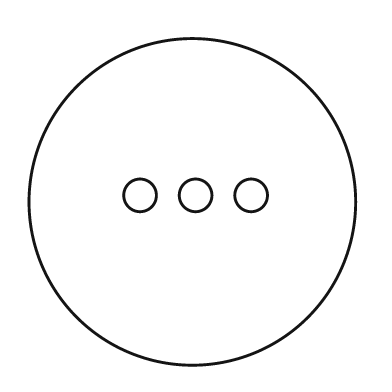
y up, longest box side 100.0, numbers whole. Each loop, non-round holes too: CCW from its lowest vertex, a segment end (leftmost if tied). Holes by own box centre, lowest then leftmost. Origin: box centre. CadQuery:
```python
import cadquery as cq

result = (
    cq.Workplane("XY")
    .moveTo(0.0, 0.0)
    .circle(50.0)
    .moveTo(-16.0, 2.0)
    .circle(5.0)
    .moveTo(1.0, 2.0)
    .circle(5.0)
    .moveTo(18.0, 2.0)
    .circle(5.0)
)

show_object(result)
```